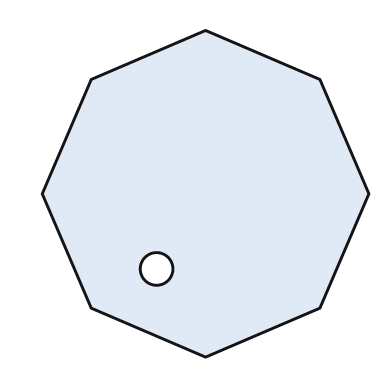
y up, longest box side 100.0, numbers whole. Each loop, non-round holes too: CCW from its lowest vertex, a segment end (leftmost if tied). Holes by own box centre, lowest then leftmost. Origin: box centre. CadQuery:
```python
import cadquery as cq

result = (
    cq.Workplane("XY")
    .moveTo(0.0, -50.0)
    .lineTo(35.0, -35.0)
    .lineTo(50.0, 0.0)
    .lineTo(35.0, 35.0)
    .lineTo(0.0, 50.0)
    .lineTo(-35.0, 35.0)
    .lineTo(-50.0, 0.0)
    .lineTo(-35.0, -35.0)
    .close()
    .moveTo(-15.0, -23.0)
    .circle(5.0)
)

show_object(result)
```